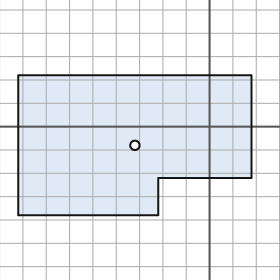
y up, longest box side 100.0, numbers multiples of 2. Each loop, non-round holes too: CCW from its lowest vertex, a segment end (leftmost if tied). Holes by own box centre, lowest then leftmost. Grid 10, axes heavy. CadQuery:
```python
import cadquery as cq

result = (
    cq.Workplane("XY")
    .moveTo(-82.0, -38.0)
    .lineTo(-22.0, -38.0)
    .lineTo(-22.0, -22.0)
    .lineTo(18.0, -22.0)
    .lineTo(18.0, 22.0)
    .lineTo(-82.0, 22.0)
    .close()
    .moveTo(-32.0, -8.0)
    .circle(2.0)
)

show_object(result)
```